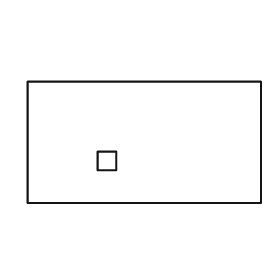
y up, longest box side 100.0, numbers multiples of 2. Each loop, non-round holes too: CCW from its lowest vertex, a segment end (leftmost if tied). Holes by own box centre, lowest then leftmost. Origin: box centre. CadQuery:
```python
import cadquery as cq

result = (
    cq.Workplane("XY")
    .moveTo(-50.0, -26.0)
    .lineTo(50.0, -26.0)
    .lineTo(50.0, 26.0)
    .lineTo(-50.0, 26.0)
    .close()
    .moveTo(-20.0, -12.0)
    .lineTo(-12.0, -12.0)
    .lineTo(-12.0, -4.0)
    .lineTo(-20.0, -4.0)
    .close()
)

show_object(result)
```